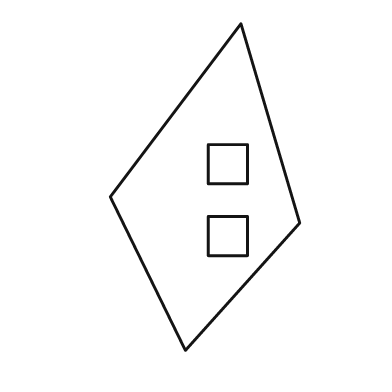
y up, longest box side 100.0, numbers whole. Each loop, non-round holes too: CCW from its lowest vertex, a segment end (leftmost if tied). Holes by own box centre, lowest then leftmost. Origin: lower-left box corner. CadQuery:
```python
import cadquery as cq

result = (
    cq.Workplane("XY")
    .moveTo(23.0, 0.0)
    .lineTo(58.0, 39.0)
    .lineTo(40.0, 100.0)
    .lineTo(0.0, 47.0)
    .close()
    .moveTo(30.0, 29.0)
    .lineTo(42.0, 29.0)
    .lineTo(42.0, 41.0)
    .lineTo(30.0, 41.0)
    .close()
    .moveTo(30.0, 51.0)
    .lineTo(42.0, 51.0)
    .lineTo(42.0, 63.0)
    .lineTo(30.0, 63.0)
    .close()
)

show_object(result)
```